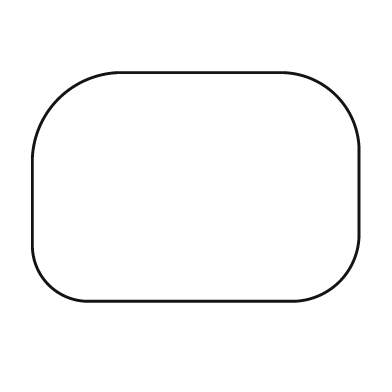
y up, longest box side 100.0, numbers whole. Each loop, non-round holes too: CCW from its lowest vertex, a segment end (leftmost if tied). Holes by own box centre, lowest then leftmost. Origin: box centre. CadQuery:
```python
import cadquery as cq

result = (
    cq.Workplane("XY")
    .moveTo(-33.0, -35.0)
    .lineTo(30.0, -35.0)
    .threePointArc((44.0, -29.0), (50.0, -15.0))
    .lineTo(50.0, 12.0)
    .threePointArc((43.0, 28.0), (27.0, 35.0))
    .lineTo(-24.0, 35.0)
    .threePointArc((-42.0, 27.0), (-50.0, 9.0))
    .lineTo(-50.0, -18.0)
    .threePointArc((-45.0, -30.0), (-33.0, -35.0))
    .close()
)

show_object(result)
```